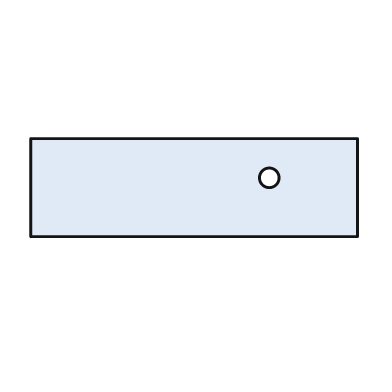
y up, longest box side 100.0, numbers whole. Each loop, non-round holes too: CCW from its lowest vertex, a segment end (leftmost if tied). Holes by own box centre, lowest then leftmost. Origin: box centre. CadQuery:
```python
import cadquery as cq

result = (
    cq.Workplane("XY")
    .moveTo(-50.0, -15.0)
    .lineTo(50.0, -15.0)
    .lineTo(50.0, 15.0)
    .lineTo(-50.0, 15.0)
    .close()
    .moveTo(23.0, 3.0)
    .circle(3.0)
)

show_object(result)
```